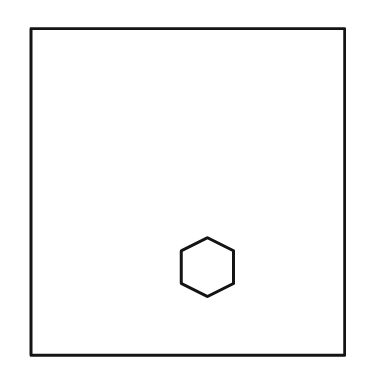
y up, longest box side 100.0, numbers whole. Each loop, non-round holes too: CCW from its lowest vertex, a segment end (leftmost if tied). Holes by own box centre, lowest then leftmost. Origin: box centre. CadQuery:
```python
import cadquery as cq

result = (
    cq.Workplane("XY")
    .moveTo(-48.0, -50.0)
    .lineTo(48.0, -50.0)
    .lineTo(48.0, 50.0)
    .lineTo(-48.0, 50.0)
    .close()
    .moveTo(6.0, -32.0)
    .lineTo(14.0, -28.0)
    .lineTo(14.0, -18.0)
    .lineTo(6.0, -14.0)
    .lineTo(-2.0, -18.0)
    .lineTo(-2.0, -28.0)
    .close()
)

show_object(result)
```